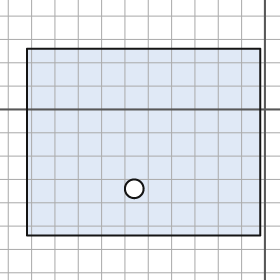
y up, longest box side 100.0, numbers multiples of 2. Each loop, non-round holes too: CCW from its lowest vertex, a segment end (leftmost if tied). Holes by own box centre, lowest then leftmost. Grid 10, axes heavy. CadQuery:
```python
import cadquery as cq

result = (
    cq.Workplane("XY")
    .moveTo(-102.0, -54.0)
    .lineTo(-2.0, -54.0)
    .lineTo(-2.0, 26.0)
    .lineTo(-102.0, 26.0)
    .close()
    .moveTo(-56.0, -34.0)
    .circle(4.0)
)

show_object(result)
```